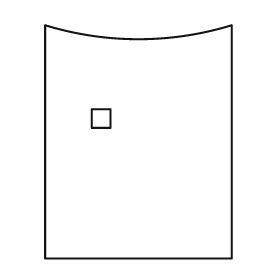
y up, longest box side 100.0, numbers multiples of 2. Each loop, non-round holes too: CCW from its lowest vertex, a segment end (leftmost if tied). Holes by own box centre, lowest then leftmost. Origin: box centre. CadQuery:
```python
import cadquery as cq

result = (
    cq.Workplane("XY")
    .moveTo(-40.0, -50.0)
    .lineTo(40.0, -50.0)
    .lineTo(40.0, 50.0)
    .threePointArc((0.0, 44.0), (-40.0, 50.0))
    .close()
    .moveTo(-20.0, 6.0)
    .lineTo(-12.0, 6.0)
    .lineTo(-12.0, 14.0)
    .lineTo(-20.0, 14.0)
    .close()
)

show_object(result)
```